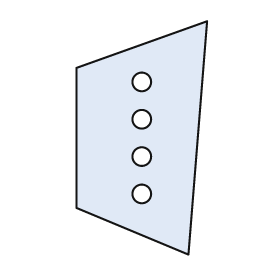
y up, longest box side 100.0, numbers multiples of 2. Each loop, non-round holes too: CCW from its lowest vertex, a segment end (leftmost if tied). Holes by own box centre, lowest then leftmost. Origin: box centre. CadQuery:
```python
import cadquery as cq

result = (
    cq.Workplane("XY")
    .moveTo(20.0, -50.0)
    .lineTo(28.0, 50.0)
    .lineTo(-28.0, 30.0)
    .lineTo(-28.0, -30.0)
    .close()
    .moveTo(0.0, -24.0)
    .circle(4.0)
    .moveTo(0.0, -8.0)
    .circle(4.0)
    .moveTo(0.0, 8.0)
    .circle(4.0)
    .moveTo(0.0, 24.0)
    .circle(4.0)
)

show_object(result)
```